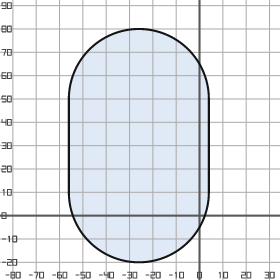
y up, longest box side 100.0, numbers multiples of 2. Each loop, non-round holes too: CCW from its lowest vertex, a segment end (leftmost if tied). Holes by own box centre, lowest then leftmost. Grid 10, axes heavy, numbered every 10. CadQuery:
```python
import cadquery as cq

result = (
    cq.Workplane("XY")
    .moveTo(-56.0, 10.0)
    .threePointArc((-26.0, -20.0), (4.0, 10.0))
    .lineTo(4.0, 50.0)
    .threePointArc((-26.0, 80.0), (-56.0, 50.0))
    .close()
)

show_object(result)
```